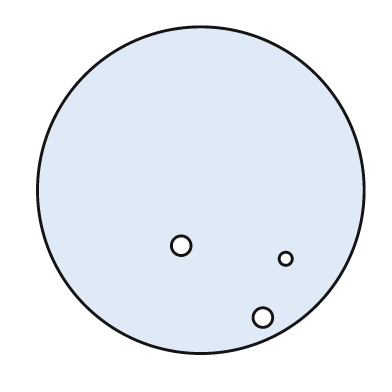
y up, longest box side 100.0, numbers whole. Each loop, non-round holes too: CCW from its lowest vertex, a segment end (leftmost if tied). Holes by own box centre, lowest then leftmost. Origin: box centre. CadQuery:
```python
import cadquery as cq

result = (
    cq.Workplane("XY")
    .moveTo(0.0, 0.0)
    .circle(50.0)
    .moveTo(19.0, -39.0)
    .circle(3.0)
    .moveTo(26.0, -21.0)
    .circle(2.0)
    .moveTo(-6.0, -17.0)
    .circle(3.0)
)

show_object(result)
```